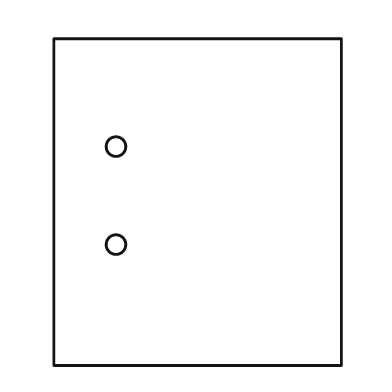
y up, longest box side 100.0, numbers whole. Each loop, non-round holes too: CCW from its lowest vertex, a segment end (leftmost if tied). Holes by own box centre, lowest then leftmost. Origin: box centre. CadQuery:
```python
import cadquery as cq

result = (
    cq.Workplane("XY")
    .moveTo(-44.0, -50.0)
    .lineTo(44.0, -50.0)
    .lineTo(44.0, 50.0)
    .lineTo(-44.0, 50.0)
    .close()
    .moveTo(-25.0, -13.0)
    .circle(3.0)
    .moveTo(-25.0, 17.0)
    .circle(3.0)
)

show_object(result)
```